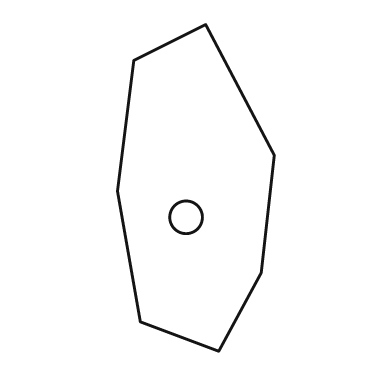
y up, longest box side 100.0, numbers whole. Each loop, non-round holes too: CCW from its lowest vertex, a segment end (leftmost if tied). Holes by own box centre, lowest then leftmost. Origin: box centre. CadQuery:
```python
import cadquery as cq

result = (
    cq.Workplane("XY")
    .moveTo(7.0, -50.0)
    .lineTo(20.0, -26.0)
    .lineTo(24.0, 10.0)
    .lineTo(3.0, 50.0)
    .lineTo(-19.0, 39.0)
    .lineTo(-24.0, -1.0)
    .lineTo(-17.0, -41.0)
    .close()
    .moveTo(-3.0, -9.0)
    .circle(5.0)
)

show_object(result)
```